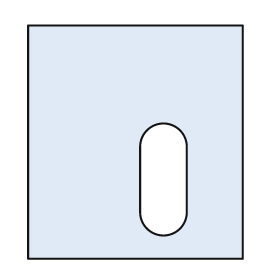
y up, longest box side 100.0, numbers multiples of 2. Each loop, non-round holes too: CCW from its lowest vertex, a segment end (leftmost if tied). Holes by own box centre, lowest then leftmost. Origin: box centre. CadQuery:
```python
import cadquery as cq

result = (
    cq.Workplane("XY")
    .moveTo(-46.0, -50.0)
    .lineTo(46.0, -50.0)
    .lineTo(46.0, 50.0)
    .lineTo(-46.0, 50.0)
    .close()
    .moveTo(2.0, -30.0)
    .threePointArc((12.0, -40.0), (22.0, -30.0))
    .lineTo(22.0, -2.0)
    .threePointArc((12.0, 8.0), (2.0, -2.0))
    .close()
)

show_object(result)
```